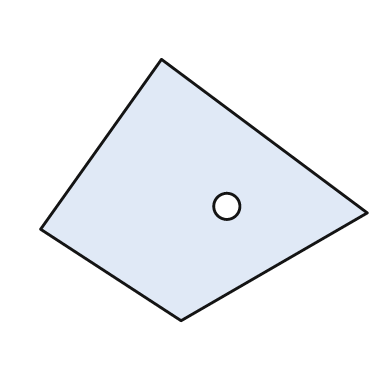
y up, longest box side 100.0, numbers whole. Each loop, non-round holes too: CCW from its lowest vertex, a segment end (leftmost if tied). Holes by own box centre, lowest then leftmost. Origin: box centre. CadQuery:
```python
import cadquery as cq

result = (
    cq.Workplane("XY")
    .moveTo(-7.0, -40.0)
    .lineTo(50.0, -7.0)
    .lineTo(-13.0, 40.0)
    .lineTo(-50.0, -12.0)
    .close()
    .moveTo(7.0, -5.0)
    .circle(4.0)
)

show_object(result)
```